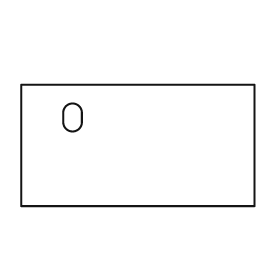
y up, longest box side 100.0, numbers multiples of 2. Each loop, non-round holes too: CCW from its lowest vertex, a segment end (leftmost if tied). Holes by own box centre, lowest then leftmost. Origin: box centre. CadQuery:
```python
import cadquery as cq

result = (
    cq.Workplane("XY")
    .moveTo(-50.0, -26.0)
    .lineTo(50.0, -26.0)
    .lineTo(50.0, 26.0)
    .lineTo(-50.0, 26.0)
    .close()
    .moveTo(-32.0, 10.0)
    .threePointArc((-28.0, 6.0), (-24.0, 10.0))
    .lineTo(-24.0, 14.0)
    .threePointArc((-28.0, 18.0), (-32.0, 14.0))
    .close()
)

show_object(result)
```